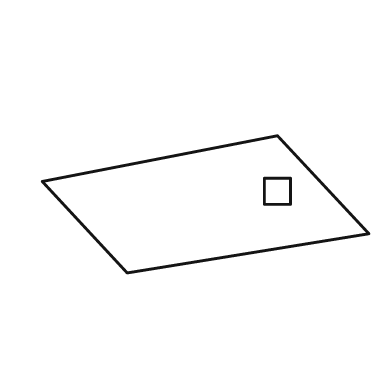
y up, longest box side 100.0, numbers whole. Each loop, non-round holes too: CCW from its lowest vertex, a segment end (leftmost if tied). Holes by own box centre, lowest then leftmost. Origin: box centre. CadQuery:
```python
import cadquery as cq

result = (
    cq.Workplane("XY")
    .moveTo(-24.0, -21.0)
    .lineTo(50.0, -9.0)
    .lineTo(22.0, 21.0)
    .lineTo(-50.0, 7.0)
    .close()
    .moveTo(18.0, 0.0)
    .lineTo(26.0, 0.0)
    .lineTo(26.0, 8.0)
    .lineTo(18.0, 8.0)
    .close()
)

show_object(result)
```